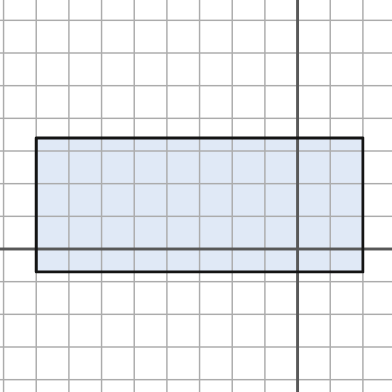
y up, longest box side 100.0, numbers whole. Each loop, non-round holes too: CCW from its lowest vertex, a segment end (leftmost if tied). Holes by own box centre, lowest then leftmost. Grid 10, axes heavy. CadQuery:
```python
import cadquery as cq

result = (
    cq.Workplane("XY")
    .moveTo(-80.0, -7.0)
    .lineTo(20.0, -7.0)
    .lineTo(20.0, 34.0)
    .lineTo(-80.0, 34.0)
    .close()
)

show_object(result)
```